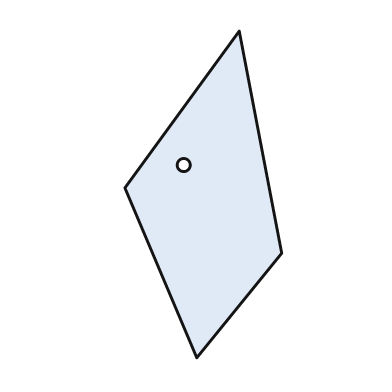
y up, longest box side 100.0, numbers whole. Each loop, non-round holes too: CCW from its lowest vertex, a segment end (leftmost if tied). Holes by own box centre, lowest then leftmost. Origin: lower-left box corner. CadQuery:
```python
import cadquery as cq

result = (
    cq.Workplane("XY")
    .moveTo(22.0, 0.0)
    .lineTo(48.0, 32.0)
    .lineTo(35.0, 100.0)
    .lineTo(0.0, 52.0)
    .close()
    .moveTo(18.0, 59.0)
    .circle(2.0)
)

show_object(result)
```